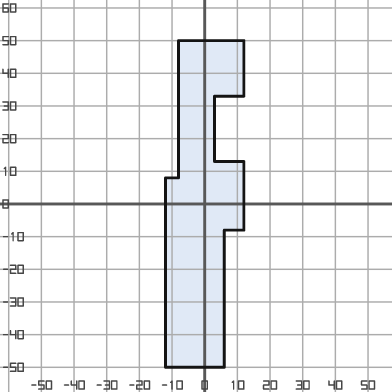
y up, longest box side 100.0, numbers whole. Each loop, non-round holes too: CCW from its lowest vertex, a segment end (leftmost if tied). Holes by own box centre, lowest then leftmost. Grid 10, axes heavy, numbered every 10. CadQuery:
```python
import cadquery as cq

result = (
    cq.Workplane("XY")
    .moveTo(-12.0, -50.0)
    .lineTo(6.0, -50.0)
    .lineTo(6.0, -8.0)
    .lineTo(12.0, -8.0)
    .lineTo(12.0, 13.0)
    .lineTo(3.0, 13.0)
    .lineTo(3.0, 33.0)
    .lineTo(12.0, 33.0)
    .lineTo(12.0, 50.0)
    .lineTo(-8.0, 50.0)
    .lineTo(-8.0, 8.0)
    .lineTo(-12.0, 8.0)
    .close()
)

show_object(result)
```